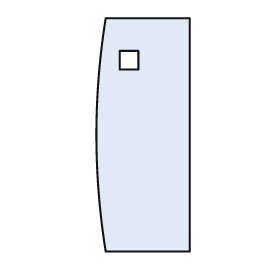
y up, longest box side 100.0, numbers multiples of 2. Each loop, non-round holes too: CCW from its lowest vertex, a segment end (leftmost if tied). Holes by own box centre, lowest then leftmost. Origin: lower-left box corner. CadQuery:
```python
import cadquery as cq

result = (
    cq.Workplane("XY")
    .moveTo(4.0, 0.0)
    .lineTo(40.0, 0.0)
    .lineTo(40.0, 100.0)
    .lineTo(4.0, 100.0)
    .threePointArc((0.0, 50.0), (4.0, 0.0))
    .close()
    .moveTo(10.0, 78.0)
    .lineTo(18.0, 78.0)
    .lineTo(18.0, 86.0)
    .lineTo(10.0, 86.0)
    .close()
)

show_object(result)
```